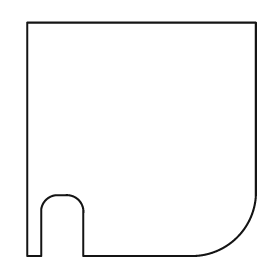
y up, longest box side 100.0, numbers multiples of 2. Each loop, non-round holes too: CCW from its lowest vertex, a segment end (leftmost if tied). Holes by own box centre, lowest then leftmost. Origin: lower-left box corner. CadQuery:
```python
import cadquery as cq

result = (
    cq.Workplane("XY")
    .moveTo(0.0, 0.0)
    .lineTo(6.0, 0.0)
    .lineTo(6.0, 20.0)
    .threePointArc((8.0, 24.0), (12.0, 26.0))
    .lineTo(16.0, 26.0)
    .threePointArc((22.0, 24.0), (24.0, 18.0))
    .lineTo(24.0, 0.0)
    .lineTo(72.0, 0.0)
    .threePointArc((90.0, 8.0), (98.0, 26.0))
    .lineTo(98.0, 100.0)
    .lineTo(0.0, 100.0)
    .close()
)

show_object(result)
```